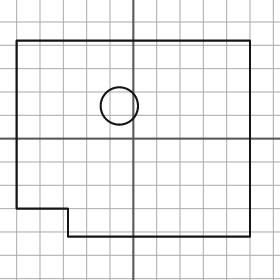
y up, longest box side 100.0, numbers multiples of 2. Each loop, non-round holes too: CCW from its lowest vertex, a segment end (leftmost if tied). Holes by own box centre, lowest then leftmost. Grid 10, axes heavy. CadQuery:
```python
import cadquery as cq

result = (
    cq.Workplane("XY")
    .moveTo(-28.0, -42.0)
    .lineTo(50.0, -42.0)
    .lineTo(50.0, 42.0)
    .lineTo(-50.0, 42.0)
    .lineTo(-50.0, -30.0)
    .lineTo(-28.0, -30.0)
    .close()
    .moveTo(-6.0, 14.0)
    .circle(8.0)
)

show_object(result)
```